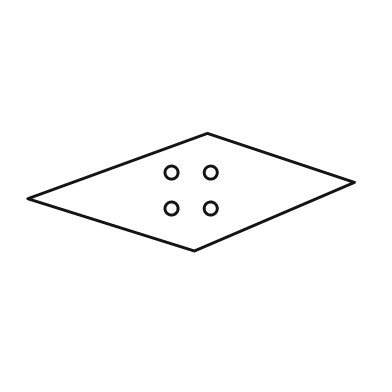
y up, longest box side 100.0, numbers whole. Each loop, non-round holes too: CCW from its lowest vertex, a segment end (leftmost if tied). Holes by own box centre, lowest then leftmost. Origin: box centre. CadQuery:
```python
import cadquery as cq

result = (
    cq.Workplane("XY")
    .moveTo(1.0, -18.0)
    .lineTo(50.0, 3.0)
    .lineTo(5.0, 18.0)
    .lineTo(-50.0, -2.0)
    .close()
    .moveTo(-6.0, -5.0)
    .circle(2.0)
    .moveTo(6.0, -5.0)
    .circle(2.0)
    .moveTo(-6.0, 6.0)
    .circle(2.0)
    .moveTo(6.0, 6.0)
    .circle(2.0)
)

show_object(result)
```